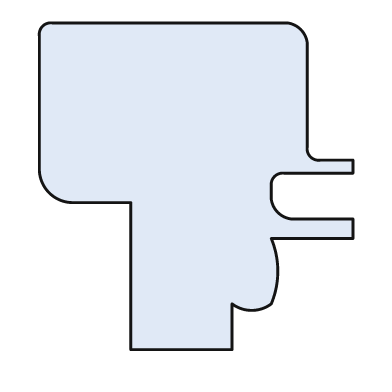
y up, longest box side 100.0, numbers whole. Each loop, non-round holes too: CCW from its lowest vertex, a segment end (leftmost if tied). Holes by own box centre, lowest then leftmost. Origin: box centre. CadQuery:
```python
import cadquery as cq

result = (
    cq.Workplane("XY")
    .moveTo(-20.0, -50.0)
    .lineTo(11.0, -50.0)
    .lineTo(11.0, -36.0)
    .threePointArc((17.0, -38.0), (23.0, -36.0))
    .threePointArc((25.0, -26.0), (23.0, -16.0))
    .lineTo(48.0, -16.0)
    .lineTo(48.0, -10.0)
    .lineTo(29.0, -10.0)
    .threePointArc((25.0, -8.0), (23.0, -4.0))
    .lineTo(23.0, 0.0)
    .threePointArc((24.0, 3.0), (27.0, 4.0))
    .lineTo(48.0, 4.0)
    .lineTo(48.0, 8.0)
    .lineTo(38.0, 8.0)
    .threePointArc((35.0, 9.0), (34.0, 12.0))
    .lineTo(34.0, 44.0)
    .threePointArc((32.0, 48.0), (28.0, 50.0))
    .lineTo(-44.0, 50.0)
    .threePointArc((-47.0, 49.0), (-48.0, 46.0))
    .lineTo(-48.0, 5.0)
    .threePointArc((-45.0, -2.0), (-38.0, -5.0))
    .lineTo(-20.0, -5.0)
    .close()
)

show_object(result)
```